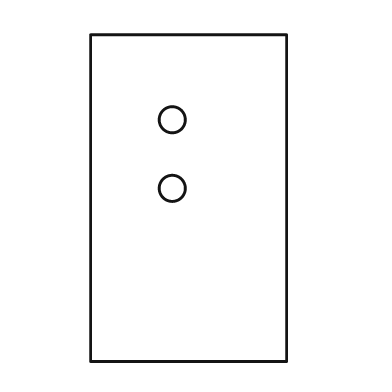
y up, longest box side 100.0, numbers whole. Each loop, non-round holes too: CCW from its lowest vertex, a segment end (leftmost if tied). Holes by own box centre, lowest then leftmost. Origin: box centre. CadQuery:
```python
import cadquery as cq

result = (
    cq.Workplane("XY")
    .moveTo(-30.0, -50.0)
    .lineTo(30.0, -50.0)
    .lineTo(30.0, 50.0)
    .lineTo(-30.0, 50.0)
    .close()
    .moveTo(-5.0, 3.0)
    .circle(4.0)
    .moveTo(-5.0, 24.0)
    .circle(4.0)
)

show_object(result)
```